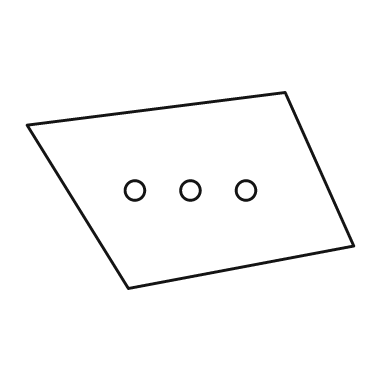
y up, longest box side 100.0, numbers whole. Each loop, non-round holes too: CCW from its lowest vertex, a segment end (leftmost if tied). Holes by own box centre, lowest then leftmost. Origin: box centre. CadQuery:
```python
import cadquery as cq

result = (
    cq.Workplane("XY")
    .moveTo(-19.0, -30.0)
    .lineTo(50.0, -17.0)
    .lineTo(29.0, 30.0)
    .lineTo(-50.0, 20.0)
    .close()
    .moveTo(-17.0, 0.0)
    .circle(3.0)
    .moveTo(0.0, 0.0)
    .circle(3.0)
    .moveTo(17.0, 0.0)
    .circle(3.0)
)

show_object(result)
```